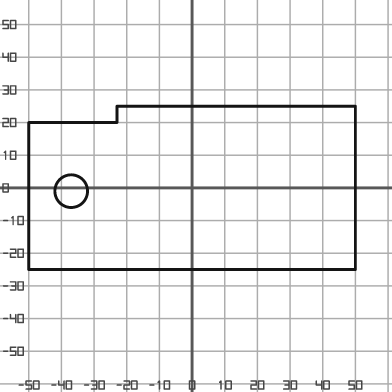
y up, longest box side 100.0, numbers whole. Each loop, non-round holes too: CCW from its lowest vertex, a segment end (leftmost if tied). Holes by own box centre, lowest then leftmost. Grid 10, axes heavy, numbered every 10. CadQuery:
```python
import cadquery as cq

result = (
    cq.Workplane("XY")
    .moveTo(-50.0, -25.0)
    .lineTo(50.0, -25.0)
    .lineTo(50.0, 25.0)
    .lineTo(-23.0, 25.0)
    .lineTo(-23.0, 20.0)
    .lineTo(-50.0, 20.0)
    .close()
    .moveTo(-37.0, -1.0)
    .circle(5.0)
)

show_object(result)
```